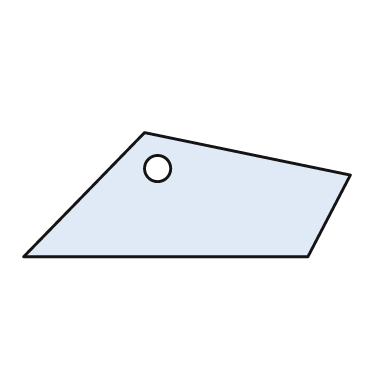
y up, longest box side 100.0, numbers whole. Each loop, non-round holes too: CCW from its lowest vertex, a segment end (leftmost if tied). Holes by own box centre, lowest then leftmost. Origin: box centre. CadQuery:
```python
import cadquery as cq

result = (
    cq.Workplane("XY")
    .moveTo(-50.0, -19.0)
    .lineTo(37.0, -19.0)
    .lineTo(50.0, 6.0)
    .lineTo(-13.0, 19.0)
    .close()
    .moveTo(-9.0, 8.0)
    .circle(4.0)
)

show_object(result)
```